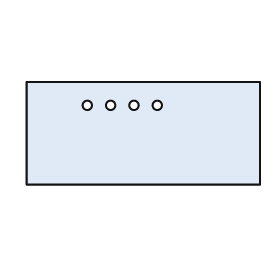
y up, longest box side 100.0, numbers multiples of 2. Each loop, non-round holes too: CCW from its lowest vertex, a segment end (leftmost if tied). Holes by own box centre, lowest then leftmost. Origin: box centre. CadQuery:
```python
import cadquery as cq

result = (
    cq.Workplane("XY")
    .moveTo(-50.0, -22.0)
    .lineTo(50.0, -22.0)
    .lineTo(50.0, 22.0)
    .lineTo(-50.0, 22.0)
    .close()
    .moveTo(-24.0, 12.0)
    .circle(2.0)
    .moveTo(-14.0, 12.0)
    .circle(2.0)
    .moveTo(-4.0, 12.0)
    .circle(2.0)
    .moveTo(6.0, 12.0)
    .circle(2.0)
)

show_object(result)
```